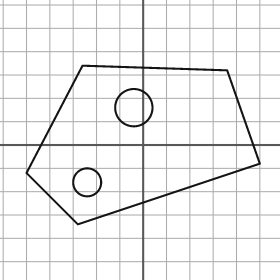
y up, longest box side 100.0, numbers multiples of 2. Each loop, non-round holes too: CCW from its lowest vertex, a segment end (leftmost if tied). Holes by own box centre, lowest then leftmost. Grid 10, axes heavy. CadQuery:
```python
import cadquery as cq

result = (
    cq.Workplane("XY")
    .moveTo(-28.0, -34.0)
    .lineTo(50.0, -8.0)
    .lineTo(36.0, 32.0)
    .lineTo(-26.0, 34.0)
    .lineTo(-50.0, -12.0)
    .close()
    .moveTo(-24.0, -16.0)
    .circle(6.0)
    .moveTo(-4.0, 16.0)
    .circle(8.0)
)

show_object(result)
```